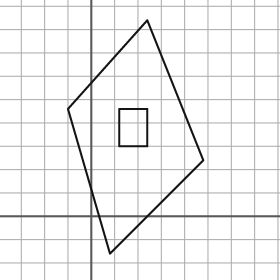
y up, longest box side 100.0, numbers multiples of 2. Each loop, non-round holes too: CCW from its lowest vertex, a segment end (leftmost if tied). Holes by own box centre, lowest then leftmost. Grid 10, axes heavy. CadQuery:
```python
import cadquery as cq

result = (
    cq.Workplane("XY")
    .moveTo(8.0, -16.0)
    .lineTo(48.0, 24.0)
    .lineTo(24.0, 84.0)
    .lineTo(-10.0, 46.0)
    .close()
    .moveTo(12.0, 30.0)
    .lineTo(24.0, 30.0)
    .lineTo(24.0, 46.0)
    .lineTo(12.0, 46.0)
    .close()
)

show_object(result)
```